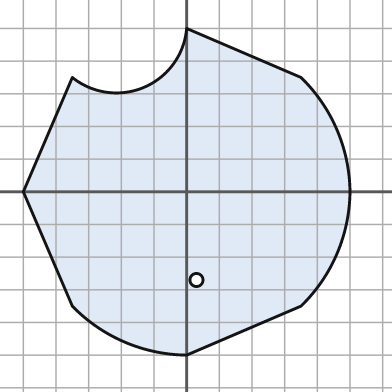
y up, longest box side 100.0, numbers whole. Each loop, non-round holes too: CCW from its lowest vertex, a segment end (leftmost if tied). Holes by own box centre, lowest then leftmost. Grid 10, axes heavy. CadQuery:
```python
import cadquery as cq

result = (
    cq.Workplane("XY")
    .moveTo(0.0, -50.0)
    .lineTo(35.0, -35.0)
    .threePointArc((46.0, -19.0), (50.0, 0.0))
    .threePointArc((46.0, 19.0), (35.0, 35.0))
    .lineTo(0.0, 50.0)
    .threePointArc((-13.0, 32.0), (-35.0, 35.0))
    .lineTo(-50.0, 0.0)
    .lineTo(-35.0, -35.0)
    .threePointArc((-19.0, -46.0), (0.0, -50.0))
    .close()
    .moveTo(3.0, -27.0)
    .circle(2.0)
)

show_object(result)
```